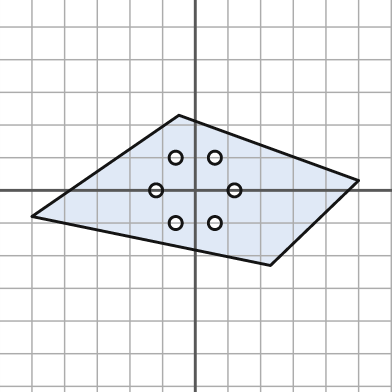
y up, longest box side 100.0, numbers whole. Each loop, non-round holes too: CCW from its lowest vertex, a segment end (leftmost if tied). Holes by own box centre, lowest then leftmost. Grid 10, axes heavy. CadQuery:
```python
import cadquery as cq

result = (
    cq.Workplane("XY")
    .moveTo(23.0, -23.0)
    .lineTo(50.0, 3.0)
    .lineTo(-5.0, 23.0)
    .lineTo(-50.0, -8.0)
    .close()
    .moveTo(-6.0, -10.0)
    .circle(2.0)
    .moveTo(6.0, -10.0)
    .circle(2.0)
    .moveTo(-12.0, 0.0)
    .circle(2.0)
    .moveTo(12.0, 0.0)
    .circle(2.0)
    .moveTo(-6.0, 10.0)
    .circle(2.0)
    .moveTo(6.0, 10.0)
    .circle(2.0)
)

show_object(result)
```